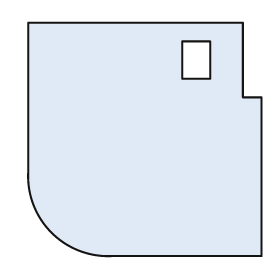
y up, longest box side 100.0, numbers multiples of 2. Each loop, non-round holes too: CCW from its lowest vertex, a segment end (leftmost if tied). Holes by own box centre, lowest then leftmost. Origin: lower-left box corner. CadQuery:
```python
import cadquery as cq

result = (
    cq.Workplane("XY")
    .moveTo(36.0, 0.0)
    .lineTo(100.0, 0.0)
    .lineTo(100.0, 68.0)
    .lineTo(92.0, 68.0)
    .lineTo(92.0, 100.0)
    .lineTo(0.0, 100.0)
    .lineTo(0.0, 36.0)
    .threePointArc((10.0, 10.0), (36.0, 0.0))
    .close()
    .moveTo(66.0, 76.0)
    .lineTo(78.0, 76.0)
    .lineTo(78.0, 92.0)
    .lineTo(66.0, 92.0)
    .close()
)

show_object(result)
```